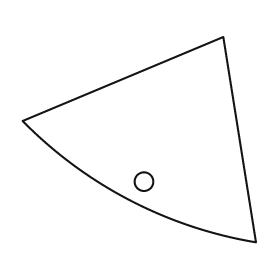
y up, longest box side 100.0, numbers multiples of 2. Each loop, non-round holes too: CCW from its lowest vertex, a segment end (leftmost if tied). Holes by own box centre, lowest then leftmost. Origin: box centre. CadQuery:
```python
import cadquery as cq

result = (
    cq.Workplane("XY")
    .moveTo(50.0, -44.0)
    .lineTo(36.0, 44.0)
    .lineTo(-50.0, 8.0)
    .threePointArc((-4.0, -26.0), (50.0, -44.0))
    .close()
    .moveTo(2.0, -18.0)
    .circle(4.0)
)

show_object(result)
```